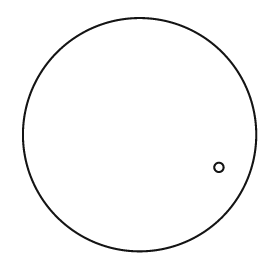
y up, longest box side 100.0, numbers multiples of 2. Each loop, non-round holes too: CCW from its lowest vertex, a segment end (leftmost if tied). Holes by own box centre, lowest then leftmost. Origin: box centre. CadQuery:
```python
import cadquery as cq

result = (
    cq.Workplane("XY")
    .moveTo(0.0, 0.0)
    .circle(50.0)
    .moveTo(34.0, -14.0)
    .circle(2.0)
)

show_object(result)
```